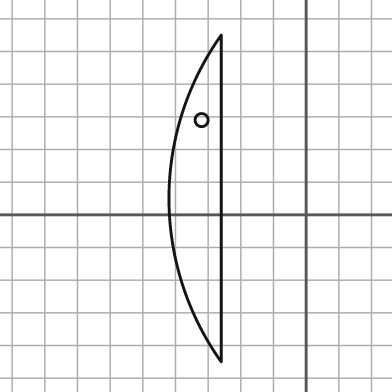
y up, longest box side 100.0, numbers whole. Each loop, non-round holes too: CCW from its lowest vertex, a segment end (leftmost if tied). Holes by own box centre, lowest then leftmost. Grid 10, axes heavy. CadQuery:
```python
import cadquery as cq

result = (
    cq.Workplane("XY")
    .moveTo(-26.0, -45.0)
    .lineTo(-26.0, 55.0)
    .threePointArc((-42.0, 5.0), (-26.0, -45.0))
    .close()
    .moveTo(-32.0, 29.0)
    .circle(2.0)
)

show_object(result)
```